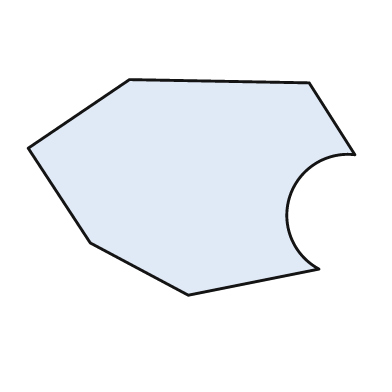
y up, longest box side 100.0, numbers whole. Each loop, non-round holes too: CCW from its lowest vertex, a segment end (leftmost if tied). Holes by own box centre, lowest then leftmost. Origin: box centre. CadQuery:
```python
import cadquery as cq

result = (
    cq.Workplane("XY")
    .moveTo(-1.0, -33.0)
    .lineTo(39.0, -25.0)
    .threePointArc((30.0, -3.0), (50.0, 10.0))
    .lineTo(36.0, 32.0)
    .lineTo(-19.0, 33.0)
    .lineTo(-50.0, 12.0)
    .lineTo(-31.0, -17.0)
    .close()
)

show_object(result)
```